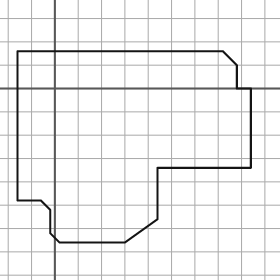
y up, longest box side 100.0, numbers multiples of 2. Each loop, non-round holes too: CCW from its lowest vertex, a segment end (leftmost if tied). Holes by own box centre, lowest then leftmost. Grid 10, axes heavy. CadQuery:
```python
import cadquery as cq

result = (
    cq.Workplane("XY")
    .moveTo(2.0, -66.0)
    .lineTo(30.0, -66.0)
    .lineTo(44.0, -56.0)
    .lineTo(44.0, -34.0)
    .lineTo(84.0, -34.0)
    .lineTo(84.0, 0.0)
    .lineTo(78.0, 0.0)
    .lineTo(78.0, 10.0)
    .lineTo(72.0, 16.0)
    .lineTo(-16.0, 16.0)
    .lineTo(-16.0, -48.0)
    .lineTo(-6.0, -48.0)
    .lineTo(-2.0, -52.0)
    .lineTo(-2.0, -62.0)
    .close()
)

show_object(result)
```